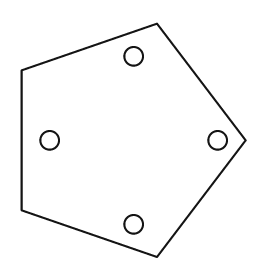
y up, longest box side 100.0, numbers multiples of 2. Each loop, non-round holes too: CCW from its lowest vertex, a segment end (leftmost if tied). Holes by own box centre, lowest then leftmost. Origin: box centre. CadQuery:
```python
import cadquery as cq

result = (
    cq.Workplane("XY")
    .moveTo(10.0, -50.0)
    .lineTo(48.0, 0.0)
    .lineTo(10.0, 50.0)
    .lineTo(-48.0, 30.0)
    .lineTo(-48.0, -30.0)
    .close()
    .moveTo(0.0, -36.0)
    .circle(4.0)
    .moveTo(-36.0, 0.0)
    .circle(4.0)
    .moveTo(36.0, 0.0)
    .circle(4.0)
    .moveTo(0.0, 36.0)
    .circle(4.0)
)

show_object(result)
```